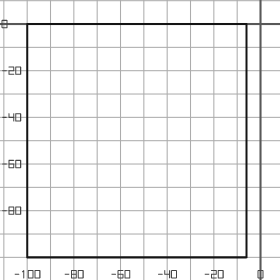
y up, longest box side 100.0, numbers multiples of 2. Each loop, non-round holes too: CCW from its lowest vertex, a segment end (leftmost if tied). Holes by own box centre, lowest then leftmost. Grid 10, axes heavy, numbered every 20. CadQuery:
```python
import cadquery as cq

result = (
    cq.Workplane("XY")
    .moveTo(-100.0, -100.0)
    .lineTo(-6.0, -100.0)
    .lineTo(-6.0, 0.0)
    .lineTo(-100.0, 0.0)
    .close()
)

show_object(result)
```